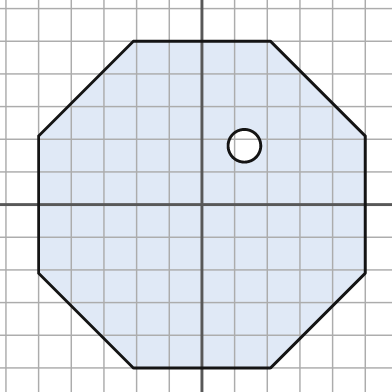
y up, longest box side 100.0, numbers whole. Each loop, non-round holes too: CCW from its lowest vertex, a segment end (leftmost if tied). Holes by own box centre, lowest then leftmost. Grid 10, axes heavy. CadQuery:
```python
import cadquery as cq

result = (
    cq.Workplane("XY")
    .moveTo(-21.0, -50.0)
    .lineTo(21.0, -50.0)
    .lineTo(50.0, -21.0)
    .lineTo(50.0, 21.0)
    .lineTo(21.0, 50.0)
    .lineTo(-21.0, 50.0)
    .lineTo(-50.0, 21.0)
    .lineTo(-50.0, -21.0)
    .close()
    .moveTo(13.0, 18.0)
    .circle(5.0)
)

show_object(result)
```